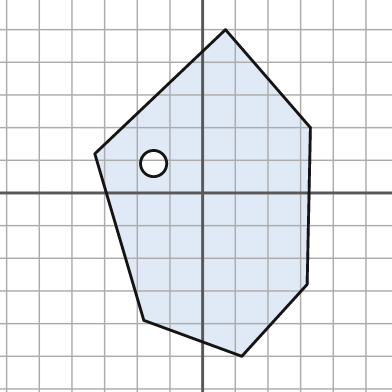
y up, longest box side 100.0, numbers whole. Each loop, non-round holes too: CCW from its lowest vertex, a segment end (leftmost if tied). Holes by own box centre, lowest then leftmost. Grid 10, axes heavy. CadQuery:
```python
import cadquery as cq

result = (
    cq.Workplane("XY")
    .moveTo(12.0, -50.0)
    .lineTo(32.0, -28.0)
    .lineTo(33.0, 20.0)
    .lineTo(7.0, 50.0)
    .lineTo(-33.0, 12.0)
    .lineTo(-18.0, -39.0)
    .close()
    .moveTo(-15.0, 9.0)
    .circle(4.0)
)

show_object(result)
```